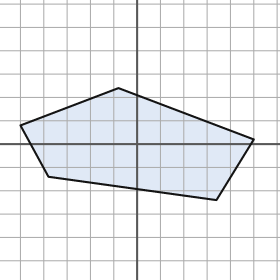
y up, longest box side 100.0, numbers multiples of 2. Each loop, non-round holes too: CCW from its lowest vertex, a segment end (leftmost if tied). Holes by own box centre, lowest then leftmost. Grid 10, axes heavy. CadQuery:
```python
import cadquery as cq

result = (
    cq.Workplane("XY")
    .moveTo(34.0, -24.0)
    .lineTo(50.0, 2.0)
    .lineTo(-8.0, 24.0)
    .lineTo(-50.0, 8.0)
    .lineTo(-38.0, -14.0)
    .close()
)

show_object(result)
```